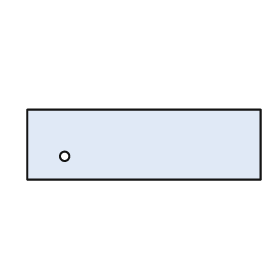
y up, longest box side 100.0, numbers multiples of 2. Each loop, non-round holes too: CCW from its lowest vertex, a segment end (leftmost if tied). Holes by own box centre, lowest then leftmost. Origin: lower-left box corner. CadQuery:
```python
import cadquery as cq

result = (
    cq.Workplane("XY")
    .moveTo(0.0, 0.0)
    .lineTo(100.0, 0.0)
    .lineTo(100.0, 30.0)
    .lineTo(0.0, 30.0)
    .close()
    .moveTo(16.0, 10.0)
    .circle(2.0)
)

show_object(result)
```